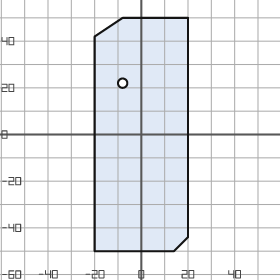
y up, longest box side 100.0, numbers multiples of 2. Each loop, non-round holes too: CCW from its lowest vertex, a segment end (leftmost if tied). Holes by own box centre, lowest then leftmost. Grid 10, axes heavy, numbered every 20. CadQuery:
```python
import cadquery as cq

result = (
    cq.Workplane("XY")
    .moveTo(-20.0, -50.0)
    .lineTo(14.0, -50.0)
    .lineTo(20.0, -44.0)
    .lineTo(20.0, 50.0)
    .lineTo(-8.0, 50.0)
    .lineTo(-20.0, 42.0)
    .close()
    .moveTo(-8.0, 22.0)
    .circle(2.0)
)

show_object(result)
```